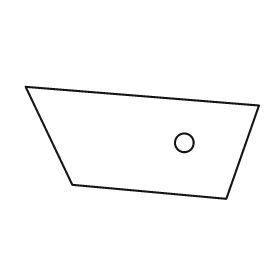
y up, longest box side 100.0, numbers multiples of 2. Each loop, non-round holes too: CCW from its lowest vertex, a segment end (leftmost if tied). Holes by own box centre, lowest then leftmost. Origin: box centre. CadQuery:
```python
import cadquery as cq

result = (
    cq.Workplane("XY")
    .moveTo(36.0, -24.0)
    .lineTo(50.0, 16.0)
    .lineTo(-50.0, 24.0)
    .lineTo(-30.0, -18.0)
    .close()
    .moveTo(18.0, 0.0)
    .circle(4.0)
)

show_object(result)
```